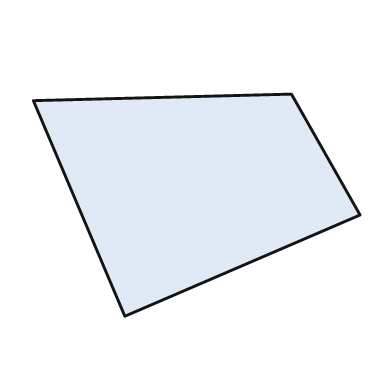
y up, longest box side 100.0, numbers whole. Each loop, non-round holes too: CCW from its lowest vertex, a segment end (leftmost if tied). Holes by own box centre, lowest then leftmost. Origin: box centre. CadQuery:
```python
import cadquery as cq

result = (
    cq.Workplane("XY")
    .moveTo(-22.0, -34.0)
    .lineTo(50.0, -3.0)
    .lineTo(29.0, 34.0)
    .lineTo(-50.0, 32.0)
    .close()
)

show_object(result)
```